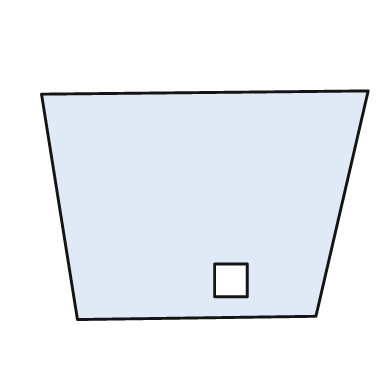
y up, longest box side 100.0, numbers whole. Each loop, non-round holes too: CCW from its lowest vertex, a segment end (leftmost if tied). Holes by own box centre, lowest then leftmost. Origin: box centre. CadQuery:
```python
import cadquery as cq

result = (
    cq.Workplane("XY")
    .moveTo(-39.0, -35.0)
    .lineTo(34.0, -34.0)
    .lineTo(50.0, 35.0)
    .lineTo(-50.0, 34.0)
    .close()
    .moveTo(3.0, -28.0)
    .lineTo(13.0, -28.0)
    .lineTo(13.0, -18.0)
    .lineTo(3.0, -18.0)
    .close()
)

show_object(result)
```